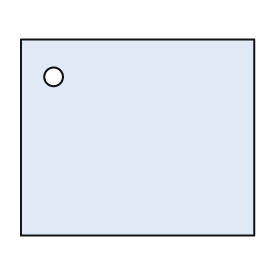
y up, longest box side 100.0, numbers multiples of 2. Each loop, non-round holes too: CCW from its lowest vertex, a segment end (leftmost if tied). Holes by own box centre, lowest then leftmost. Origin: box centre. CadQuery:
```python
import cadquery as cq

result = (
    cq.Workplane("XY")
    .moveTo(-50.0, -42.0)
    .lineTo(50.0, -42.0)
    .lineTo(50.0, 42.0)
    .lineTo(-50.0, 42.0)
    .close()
    .moveTo(-36.0, 26.0)
    .circle(4.0)
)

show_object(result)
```